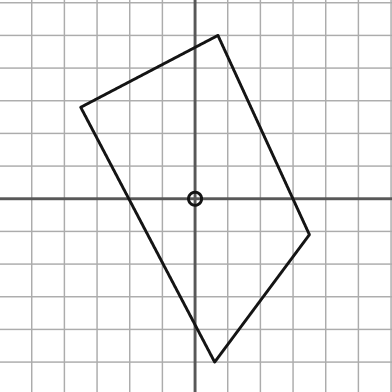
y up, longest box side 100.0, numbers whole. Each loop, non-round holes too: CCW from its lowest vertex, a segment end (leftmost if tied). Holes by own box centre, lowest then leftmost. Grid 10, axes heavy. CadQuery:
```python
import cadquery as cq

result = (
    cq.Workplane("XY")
    .moveTo(6.0, -50.0)
    .lineTo(35.0, -11.0)
    .lineTo(7.0, 50.0)
    .lineTo(-35.0, 28.0)
    .close()
    .moveTo(0.0, 0.0)
    .circle(2.0)
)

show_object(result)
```